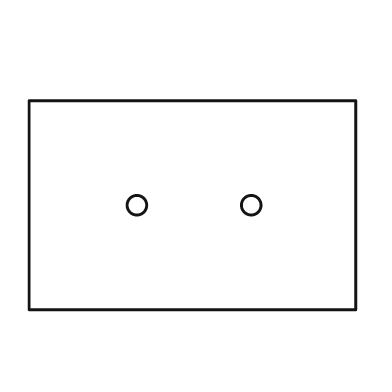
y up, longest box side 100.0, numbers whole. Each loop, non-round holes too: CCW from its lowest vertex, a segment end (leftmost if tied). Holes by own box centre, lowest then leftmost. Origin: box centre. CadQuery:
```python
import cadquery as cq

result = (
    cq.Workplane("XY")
    .moveTo(-50.0, -32.0)
    .lineTo(50.0, -32.0)
    .lineTo(50.0, 32.0)
    .lineTo(-50.0, 32.0)
    .close()
    .moveTo(-17.0, 0.0)
    .circle(3.0)
    .moveTo(18.0, 0.0)
    .circle(3.0)
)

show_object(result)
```